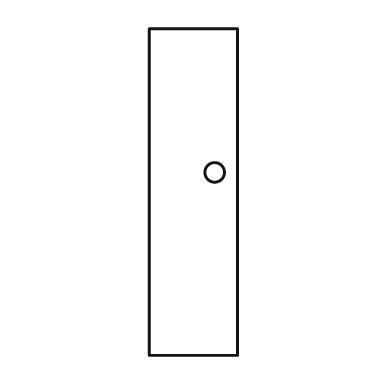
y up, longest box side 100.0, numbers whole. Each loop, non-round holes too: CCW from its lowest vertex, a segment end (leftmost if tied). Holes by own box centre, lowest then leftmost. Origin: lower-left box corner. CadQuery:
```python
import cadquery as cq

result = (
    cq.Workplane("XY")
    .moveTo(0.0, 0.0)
    .lineTo(27.0, 0.0)
    .lineTo(27.0, 100.0)
    .lineTo(0.0, 100.0)
    .close()
    .moveTo(20.0, 56.0)
    .circle(3.0)
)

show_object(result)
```